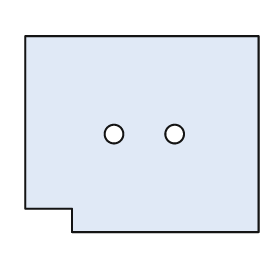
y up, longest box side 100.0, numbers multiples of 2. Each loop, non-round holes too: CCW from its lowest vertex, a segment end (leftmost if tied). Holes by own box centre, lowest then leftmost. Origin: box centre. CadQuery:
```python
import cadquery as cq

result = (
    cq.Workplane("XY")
    .moveTo(-30.0, -42.0)
    .lineTo(50.0, -42.0)
    .lineTo(50.0, 42.0)
    .lineTo(-50.0, 42.0)
    .lineTo(-50.0, -32.0)
    .lineTo(-30.0, -32.0)
    .close()
    .moveTo(-12.0, 0.0)
    .circle(4.0)
    .moveTo(14.0, 0.0)
    .circle(4.0)
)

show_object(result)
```